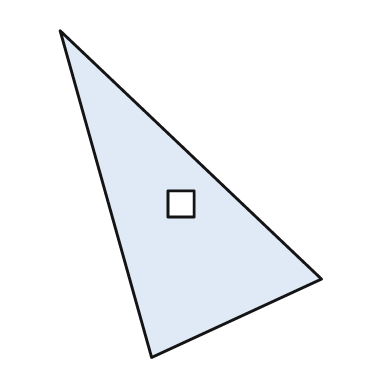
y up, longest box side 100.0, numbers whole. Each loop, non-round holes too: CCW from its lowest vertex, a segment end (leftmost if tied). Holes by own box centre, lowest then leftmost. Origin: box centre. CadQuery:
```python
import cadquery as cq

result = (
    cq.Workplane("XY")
    .moveTo(-12.0, -50.0)
    .lineTo(40.0, -26.0)
    .lineTo(-40.0, 50.0)
    .close()
    .moveTo(-7.0, -7.0)
    .lineTo(1.0, -7.0)
    .lineTo(1.0, 1.0)
    .lineTo(-7.0, 1.0)
    .close()
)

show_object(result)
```